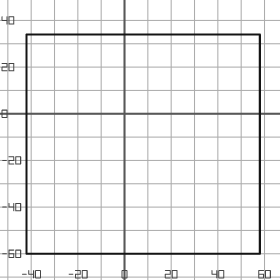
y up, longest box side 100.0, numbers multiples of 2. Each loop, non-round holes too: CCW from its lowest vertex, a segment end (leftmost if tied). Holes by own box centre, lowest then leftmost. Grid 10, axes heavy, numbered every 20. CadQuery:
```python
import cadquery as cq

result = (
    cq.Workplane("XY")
    .moveTo(-42.0, -60.0)
    .lineTo(58.0, -60.0)
    .lineTo(58.0, 34.0)
    .lineTo(-42.0, 34.0)
    .close()
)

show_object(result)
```